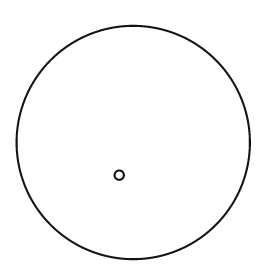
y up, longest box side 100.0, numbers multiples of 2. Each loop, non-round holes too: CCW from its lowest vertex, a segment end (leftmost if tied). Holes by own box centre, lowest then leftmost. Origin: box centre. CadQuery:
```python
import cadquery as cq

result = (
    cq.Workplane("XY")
    .moveTo(0.0, 0.0)
    .circle(50.0)
    .moveTo(-6.0, -14.0)
    .circle(2.0)
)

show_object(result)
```